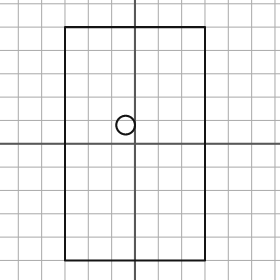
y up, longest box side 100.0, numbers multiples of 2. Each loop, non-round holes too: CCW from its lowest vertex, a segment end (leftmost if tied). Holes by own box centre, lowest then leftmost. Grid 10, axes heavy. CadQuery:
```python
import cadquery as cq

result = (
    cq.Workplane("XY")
    .moveTo(-30.0, -50.0)
    .lineTo(30.0, -50.0)
    .lineTo(30.0, 50.0)
    .lineTo(-30.0, 50.0)
    .close()
    .moveTo(-4.0, 8.0)
    .circle(4.0)
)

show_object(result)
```